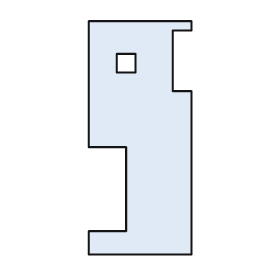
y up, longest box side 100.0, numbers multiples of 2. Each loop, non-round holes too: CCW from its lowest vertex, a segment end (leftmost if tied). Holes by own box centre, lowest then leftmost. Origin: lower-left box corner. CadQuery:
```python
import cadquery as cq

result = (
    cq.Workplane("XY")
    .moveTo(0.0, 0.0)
    .lineTo(44.0, 0.0)
    .lineTo(44.0, 70.0)
    .lineTo(36.0, 70.0)
    .lineTo(36.0, 96.0)
    .lineTo(44.0, 96.0)
    .lineTo(44.0, 100.0)
    .lineTo(0.0, 100.0)
    .lineTo(0.0, 46.0)
    .lineTo(16.0, 46.0)
    .lineTo(16.0, 10.0)
    .lineTo(0.0, 10.0)
    .close()
    .moveTo(12.0, 78.0)
    .lineTo(20.0, 78.0)
    .lineTo(20.0, 86.0)
    .lineTo(12.0, 86.0)
    .close()
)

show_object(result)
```